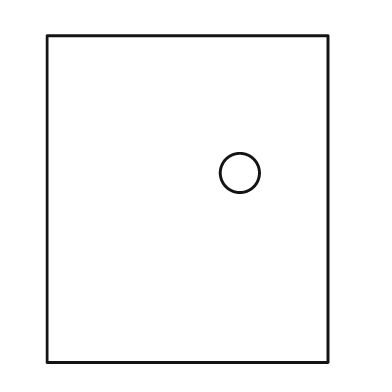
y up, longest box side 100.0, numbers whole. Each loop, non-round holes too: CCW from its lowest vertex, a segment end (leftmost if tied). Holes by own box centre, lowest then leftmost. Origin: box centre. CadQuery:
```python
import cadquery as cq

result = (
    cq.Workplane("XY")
    .moveTo(-43.0, -50.0)
    .lineTo(43.0, -50.0)
    .lineTo(43.0, 50.0)
    .lineTo(-43.0, 50.0)
    .close()
    .moveTo(16.0, 8.0)
    .circle(6.0)
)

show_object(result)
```